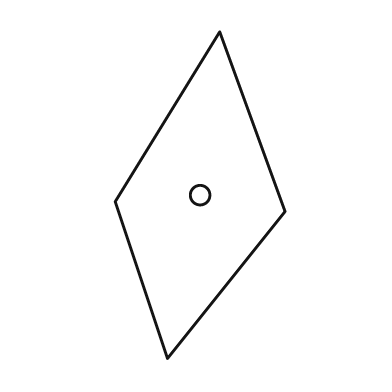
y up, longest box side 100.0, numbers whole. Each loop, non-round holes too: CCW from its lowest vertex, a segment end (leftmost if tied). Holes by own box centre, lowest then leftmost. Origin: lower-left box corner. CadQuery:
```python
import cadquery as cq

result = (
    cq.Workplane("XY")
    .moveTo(16.0, 0.0)
    .lineTo(52.0, 45.0)
    .lineTo(32.0, 100.0)
    .lineTo(0.0, 48.0)
    .close()
    .moveTo(26.0, 50.0)
    .circle(3.0)
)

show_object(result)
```